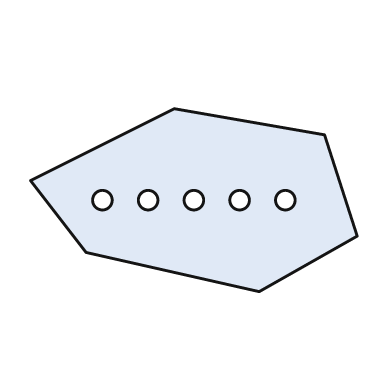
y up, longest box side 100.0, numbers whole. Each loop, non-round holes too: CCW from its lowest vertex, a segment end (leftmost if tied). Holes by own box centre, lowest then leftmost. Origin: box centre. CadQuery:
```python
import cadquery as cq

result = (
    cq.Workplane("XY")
    .moveTo(20.0, -28.0)
    .lineTo(50.0, -11.0)
    .lineTo(40.0, 20.0)
    .lineTo(-6.0, 28.0)
    .lineTo(-50.0, 6.0)
    .lineTo(-33.0, -16.0)
    .close()
    .moveTo(-28.0, 0.0)
    .circle(3.0)
    .moveTo(-14.0, 0.0)
    .circle(3.0)
    .moveTo(0.0, 0.0)
    .circle(3.0)
    .moveTo(14.0, 0.0)
    .circle(3.0)
    .moveTo(28.0, 0.0)
    .circle(3.0)
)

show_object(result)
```